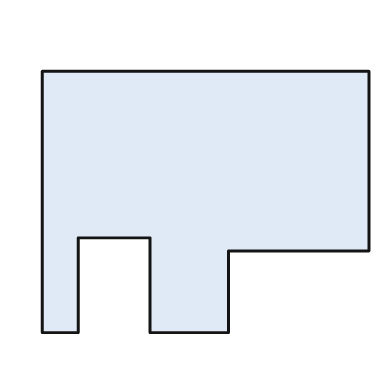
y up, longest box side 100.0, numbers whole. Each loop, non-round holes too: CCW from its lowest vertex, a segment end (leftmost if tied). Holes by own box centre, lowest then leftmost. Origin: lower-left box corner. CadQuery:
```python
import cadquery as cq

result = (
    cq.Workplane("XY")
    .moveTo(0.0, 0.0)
    .lineTo(11.0, 0.0)
    .lineTo(11.0, 29.0)
    .lineTo(33.0, 29.0)
    .lineTo(33.0, 0.0)
    .lineTo(57.0, 0.0)
    .lineTo(57.0, 25.0)
    .lineTo(100.0, 25.0)
    .lineTo(100.0, 80.0)
    .lineTo(0.0, 80.0)
    .close()
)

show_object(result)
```